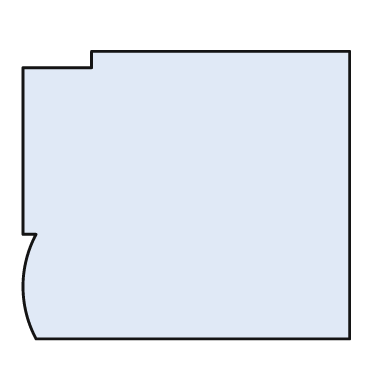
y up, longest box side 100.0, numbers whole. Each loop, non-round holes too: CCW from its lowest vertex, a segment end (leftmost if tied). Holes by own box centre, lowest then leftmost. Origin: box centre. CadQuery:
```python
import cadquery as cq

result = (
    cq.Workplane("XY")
    .moveTo(-46.0, -44.0)
    .lineTo(50.0, -44.0)
    .lineTo(50.0, 44.0)
    .lineTo(-29.0, 44.0)
    .lineTo(-29.0, 39.0)
    .lineTo(-50.0, 39.0)
    .lineTo(-50.0, -12.0)
    .lineTo(-46.0, -12.0)
    .threePointArc((-50.0, -28.0), (-46.0, -44.0))
    .close()
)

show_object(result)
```